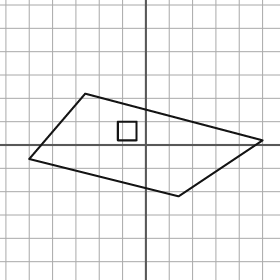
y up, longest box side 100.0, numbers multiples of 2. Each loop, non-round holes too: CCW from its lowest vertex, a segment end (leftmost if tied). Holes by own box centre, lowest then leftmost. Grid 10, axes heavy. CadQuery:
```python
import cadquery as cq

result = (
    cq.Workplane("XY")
    .moveTo(14.0, -22.0)
    .lineTo(50.0, 2.0)
    .lineTo(-26.0, 22.0)
    .lineTo(-50.0, -6.0)
    .close()
    .moveTo(-12.0, 2.0)
    .lineTo(-4.0, 2.0)
    .lineTo(-4.0, 10.0)
    .lineTo(-12.0, 10.0)
    .close()
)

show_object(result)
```